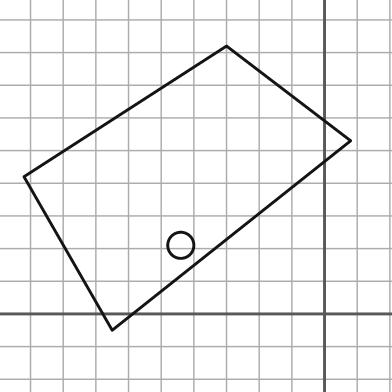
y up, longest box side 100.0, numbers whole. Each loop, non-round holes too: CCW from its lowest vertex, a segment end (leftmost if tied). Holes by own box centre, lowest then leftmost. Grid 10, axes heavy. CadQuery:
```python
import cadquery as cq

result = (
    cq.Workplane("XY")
    .moveTo(-65.0, -5.0)
    .lineTo(8.0, 53.0)
    .lineTo(-30.0, 82.0)
    .lineTo(-92.0, 42.0)
    .close()
    .moveTo(-44.0, 21.0)
    .circle(4.0)
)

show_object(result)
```